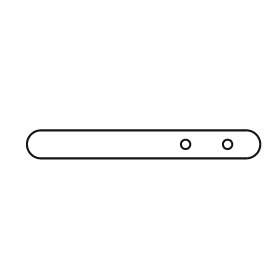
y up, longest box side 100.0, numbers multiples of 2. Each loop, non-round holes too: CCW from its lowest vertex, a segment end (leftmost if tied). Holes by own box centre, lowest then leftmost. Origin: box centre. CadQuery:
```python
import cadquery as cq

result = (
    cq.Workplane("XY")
    .moveTo(-44.0, -6.0)
    .lineTo(44.0, -6.0)
    .threePointArc((50.0, 0.0), (44.0, 6.0))
    .lineTo(-44.0, 6.0)
    .threePointArc((-50.0, 0.0), (-44.0, -6.0))
    .close()
    .moveTo(18.0, 0.0)
    .circle(2.0)
    .moveTo(36.0, 0.0)
    .circle(2.0)
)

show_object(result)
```